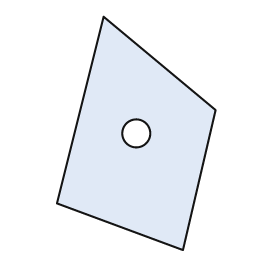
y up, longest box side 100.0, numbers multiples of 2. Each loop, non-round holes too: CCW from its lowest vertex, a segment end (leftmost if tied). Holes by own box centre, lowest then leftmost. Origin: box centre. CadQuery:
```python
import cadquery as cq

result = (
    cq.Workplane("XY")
    .moveTo(20.0, -50.0)
    .lineTo(34.0, 10.0)
    .lineTo(-14.0, 50.0)
    .lineTo(-34.0, -30.0)
    .close()
    .moveTo(0.0, 0.0)
    .circle(6.0)
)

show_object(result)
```